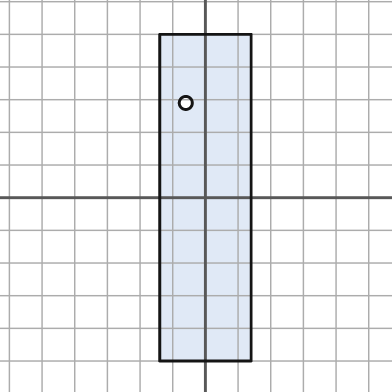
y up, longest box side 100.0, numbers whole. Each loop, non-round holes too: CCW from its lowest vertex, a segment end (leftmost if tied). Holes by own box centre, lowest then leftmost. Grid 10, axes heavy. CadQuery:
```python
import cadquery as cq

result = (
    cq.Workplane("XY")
    .moveTo(-14.0, -50.0)
    .lineTo(14.0, -50.0)
    .lineTo(14.0, 50.0)
    .lineTo(-14.0, 50.0)
    .close()
    .moveTo(-6.0, 29.0)
    .circle(2.0)
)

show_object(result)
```